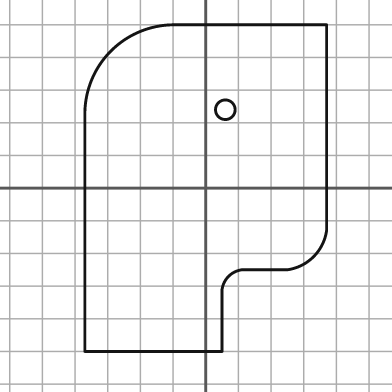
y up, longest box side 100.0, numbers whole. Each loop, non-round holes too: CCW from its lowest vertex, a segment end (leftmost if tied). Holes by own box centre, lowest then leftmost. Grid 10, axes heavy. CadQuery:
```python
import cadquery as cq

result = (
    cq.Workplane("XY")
    .moveTo(-37.0, -50.0)
    .lineTo(5.0, -50.0)
    .lineTo(5.0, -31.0)
    .threePointArc((7.0, -27.0), (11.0, -25.0))
    .lineTo(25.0, -25.0)
    .threePointArc((33.0, -21.0), (37.0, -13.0))
    .lineTo(37.0, 50.0)
    .lineTo(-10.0, 50.0)
    .threePointArc((-29.0, 42.0), (-37.0, 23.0))
    .close()
    .moveTo(6.0, 24.0)
    .circle(3.0)
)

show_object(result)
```